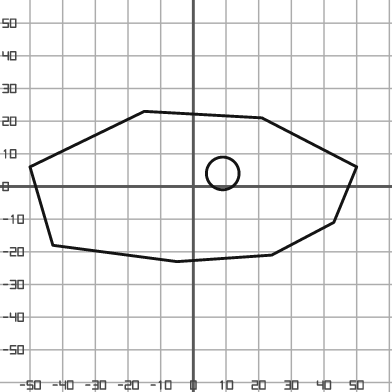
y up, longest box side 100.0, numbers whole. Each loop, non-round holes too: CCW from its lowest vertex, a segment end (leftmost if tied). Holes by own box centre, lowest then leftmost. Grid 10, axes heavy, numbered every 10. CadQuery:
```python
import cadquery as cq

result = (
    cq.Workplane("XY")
    .moveTo(-5.0, -23.0)
    .lineTo(24.0, -21.0)
    .lineTo(43.0, -11.0)
    .lineTo(50.0, 6.0)
    .lineTo(21.0, 21.0)
    .lineTo(-15.0, 23.0)
    .lineTo(-50.0, 6.0)
    .lineTo(-43.0, -18.0)
    .close()
    .moveTo(9.0, 4.0)
    .circle(5.0)
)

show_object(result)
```